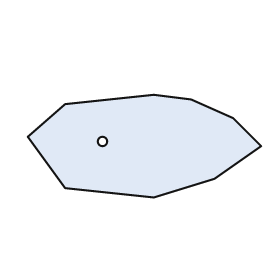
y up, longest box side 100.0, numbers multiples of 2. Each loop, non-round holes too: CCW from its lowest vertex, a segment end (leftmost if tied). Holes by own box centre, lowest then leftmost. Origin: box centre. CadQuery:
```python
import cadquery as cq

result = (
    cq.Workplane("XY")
    .moveTo(4.0, -22.0)
    .lineTo(30.0, -14.0)
    .lineTo(50.0, 0.0)
    .lineTo(38.0, 12.0)
    .lineTo(20.0, 20.0)
    .lineTo(4.0, 22.0)
    .lineTo(-34.0, 18.0)
    .lineTo(-50.0, 4.0)
    .lineTo(-34.0, -18.0)
    .close()
    .moveTo(-18.0, 2.0)
    .circle(2.0)
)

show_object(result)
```